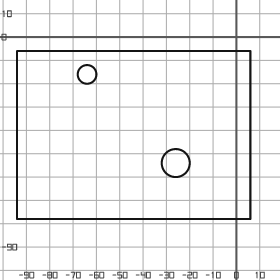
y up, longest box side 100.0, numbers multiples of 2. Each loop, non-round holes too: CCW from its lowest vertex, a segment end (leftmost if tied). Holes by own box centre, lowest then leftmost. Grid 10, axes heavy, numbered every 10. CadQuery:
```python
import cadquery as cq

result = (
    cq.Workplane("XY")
    .moveTo(-94.0, -78.0)
    .lineTo(6.0, -78.0)
    .lineTo(6.0, -6.0)
    .lineTo(-94.0, -6.0)
    .close()
    .moveTo(-26.0, -54.0)
    .circle(6.0)
    .moveTo(-64.0, -16.0)
    .circle(4.0)
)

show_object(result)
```